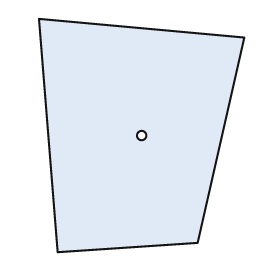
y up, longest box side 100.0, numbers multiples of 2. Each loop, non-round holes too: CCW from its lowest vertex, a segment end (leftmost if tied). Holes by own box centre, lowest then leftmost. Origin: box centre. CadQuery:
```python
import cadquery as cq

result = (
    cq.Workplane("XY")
    .moveTo(-36.0, -50.0)
    .lineTo(24.0, -46.0)
    .lineTo(44.0, 42.0)
    .lineTo(-44.0, 50.0)
    .close()
    .moveTo(0.0, 0.0)
    .circle(2.0)
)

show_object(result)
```